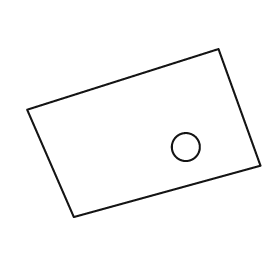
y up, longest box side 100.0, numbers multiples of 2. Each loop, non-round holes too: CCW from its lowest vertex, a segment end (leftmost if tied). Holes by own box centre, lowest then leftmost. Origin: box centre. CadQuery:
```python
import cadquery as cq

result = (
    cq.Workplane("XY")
    .moveTo(-30.0, -36.0)
    .lineTo(50.0, -14.0)
    .lineTo(32.0, 36.0)
    .lineTo(-50.0, 10.0)
    .close()
    .moveTo(18.0, -6.0)
    .circle(6.0)
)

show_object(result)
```